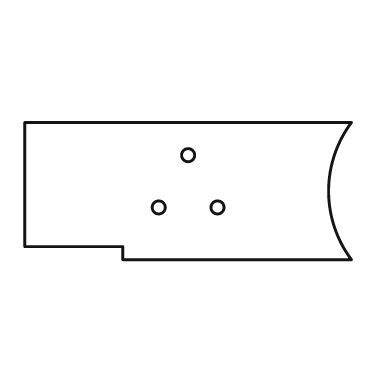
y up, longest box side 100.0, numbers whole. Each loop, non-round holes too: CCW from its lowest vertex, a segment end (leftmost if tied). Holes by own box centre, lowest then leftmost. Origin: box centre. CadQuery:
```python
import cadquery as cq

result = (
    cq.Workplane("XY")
    .moveTo(-20.0, -21.0)
    .lineTo(50.0, -21.0)
    .threePointArc((43.0, 0.0), (50.0, 21.0))
    .lineTo(-50.0, 21.0)
    .lineTo(-50.0, -17.0)
    .lineTo(-20.0, -17.0)
    .close()
    .moveTo(-9.0, -5.0)
    .circle(2.0)
    .moveTo(9.0, -5.0)
    .circle(2.0)
    .moveTo(0.0, 11.0)
    .circle(2.0)
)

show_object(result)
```